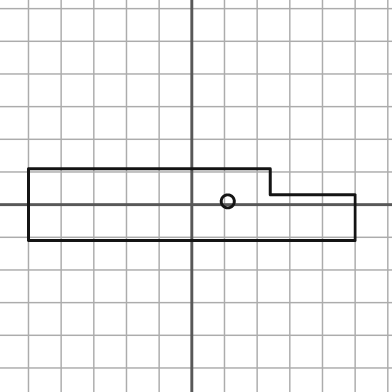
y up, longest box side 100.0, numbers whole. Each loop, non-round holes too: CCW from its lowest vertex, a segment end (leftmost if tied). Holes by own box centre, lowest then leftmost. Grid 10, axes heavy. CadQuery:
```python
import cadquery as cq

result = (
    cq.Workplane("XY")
    .moveTo(-50.0, -11.0)
    .lineTo(50.0, -11.0)
    .lineTo(50.0, 3.0)
    .lineTo(24.0, 3.0)
    .lineTo(24.0, 11.0)
    .lineTo(-50.0, 11.0)
    .close()
    .moveTo(11.0, 1.0)
    .circle(2.0)
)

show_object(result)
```